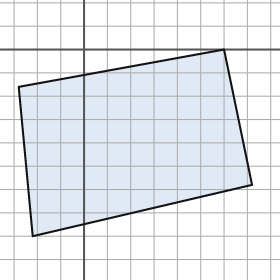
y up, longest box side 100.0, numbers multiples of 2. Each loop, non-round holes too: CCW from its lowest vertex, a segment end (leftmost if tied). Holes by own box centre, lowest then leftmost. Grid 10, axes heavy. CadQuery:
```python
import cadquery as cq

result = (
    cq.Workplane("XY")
    .moveTo(-22.0, -80.0)
    .lineTo(72.0, -58.0)
    .lineTo(60.0, 0.0)
    .lineTo(-28.0, -16.0)
    .close()
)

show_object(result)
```